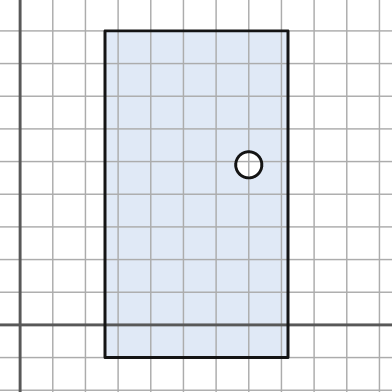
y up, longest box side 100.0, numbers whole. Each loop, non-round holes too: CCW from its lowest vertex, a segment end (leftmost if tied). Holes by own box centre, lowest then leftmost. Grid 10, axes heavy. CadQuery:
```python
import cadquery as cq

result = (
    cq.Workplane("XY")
    .moveTo(26.0, -10.0)
    .lineTo(82.0, -10.0)
    .lineTo(82.0, 90.0)
    .lineTo(26.0, 90.0)
    .close()
    .moveTo(70.0, 49.0)
    .circle(4.0)
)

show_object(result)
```